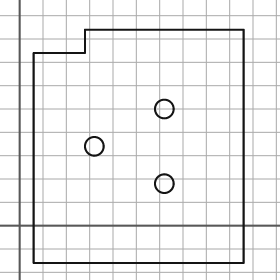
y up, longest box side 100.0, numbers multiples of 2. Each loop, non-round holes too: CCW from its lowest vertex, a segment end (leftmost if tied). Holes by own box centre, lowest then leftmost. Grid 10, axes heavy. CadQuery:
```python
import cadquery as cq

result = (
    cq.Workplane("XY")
    .moveTo(6.0, -16.0)
    .lineTo(96.0, -16.0)
    .lineTo(96.0, 84.0)
    .lineTo(28.0, 84.0)
    .lineTo(28.0, 74.0)
    .lineTo(6.0, 74.0)
    .close()
    .moveTo(62.0, 18.0)
    .circle(4.0)
    .moveTo(32.0, 34.0)
    .circle(4.0)
    .moveTo(62.0, 50.0)
    .circle(4.0)
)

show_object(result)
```